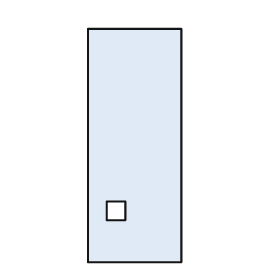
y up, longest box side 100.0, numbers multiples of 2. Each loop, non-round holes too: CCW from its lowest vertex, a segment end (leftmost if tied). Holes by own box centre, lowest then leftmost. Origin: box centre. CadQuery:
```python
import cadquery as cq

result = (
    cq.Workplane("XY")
    .moveTo(-20.0, -50.0)
    .lineTo(20.0, -50.0)
    .lineTo(20.0, 50.0)
    .lineTo(-20.0, 50.0)
    .close()
    .moveTo(-12.0, -32.0)
    .lineTo(-4.0, -32.0)
    .lineTo(-4.0, -24.0)
    .lineTo(-12.0, -24.0)
    .close()
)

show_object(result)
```